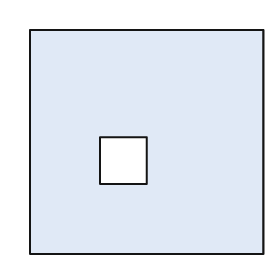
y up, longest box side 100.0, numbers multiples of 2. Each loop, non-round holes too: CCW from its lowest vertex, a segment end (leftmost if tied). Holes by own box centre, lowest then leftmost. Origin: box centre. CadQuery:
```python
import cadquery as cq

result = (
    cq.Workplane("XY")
    .moveTo(-50.0, -48.0)
    .lineTo(50.0, -48.0)
    .lineTo(50.0, 48.0)
    .lineTo(-50.0, 48.0)
    .close()
    .moveTo(-20.0, -18.0)
    .lineTo(0.0, -18.0)
    .lineTo(0.0, 2.0)
    .lineTo(-20.0, 2.0)
    .close()
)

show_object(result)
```